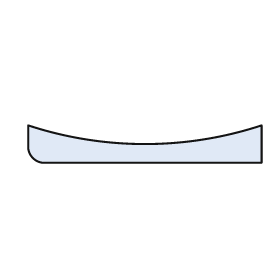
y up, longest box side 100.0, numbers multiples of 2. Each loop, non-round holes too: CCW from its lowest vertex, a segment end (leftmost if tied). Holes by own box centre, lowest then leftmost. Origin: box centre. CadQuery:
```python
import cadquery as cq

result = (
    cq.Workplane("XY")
    .moveTo(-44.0, -8.0)
    .lineTo(50.0, -8.0)
    .lineTo(50.0, 8.0)
    .threePointArc((0.0, 0.0), (-50.0, 8.0))
    .lineTo(-50.0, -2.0)
    .threePointArc((-48.0, -6.0), (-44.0, -8.0))
    .close()
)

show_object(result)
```